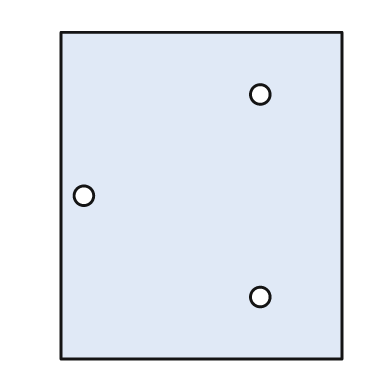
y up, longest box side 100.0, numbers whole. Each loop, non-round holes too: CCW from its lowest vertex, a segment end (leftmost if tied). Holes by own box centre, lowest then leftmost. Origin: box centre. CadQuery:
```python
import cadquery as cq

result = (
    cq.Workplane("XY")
    .moveTo(-43.0, -50.0)
    .lineTo(43.0, -50.0)
    .lineTo(43.0, 50.0)
    .lineTo(-43.0, 50.0)
    .close()
    .moveTo(18.0, -31.0)
    .circle(3.0)
    .moveTo(-36.0, 0.0)
    .circle(3.0)
    .moveTo(18.0, 31.0)
    .circle(3.0)
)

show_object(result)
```